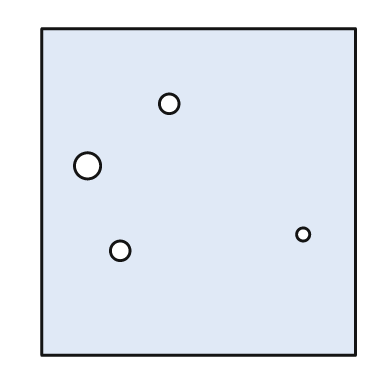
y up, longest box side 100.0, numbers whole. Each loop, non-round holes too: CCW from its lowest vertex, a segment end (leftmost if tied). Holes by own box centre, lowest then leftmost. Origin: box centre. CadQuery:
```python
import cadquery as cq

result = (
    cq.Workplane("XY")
    .moveTo(-48.0, -50.0)
    .lineTo(48.0, -50.0)
    .lineTo(48.0, 50.0)
    .lineTo(-48.0, 50.0)
    .close()
    .moveTo(-24.0, -18.0)
    .circle(3.0)
    .moveTo(32.0, -13.0)
    .circle(2.0)
    .moveTo(-34.0, 8.0)
    .circle(4.0)
    .moveTo(-9.0, 27.0)
    .circle(3.0)
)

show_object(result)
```